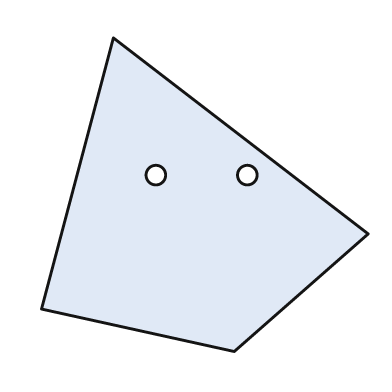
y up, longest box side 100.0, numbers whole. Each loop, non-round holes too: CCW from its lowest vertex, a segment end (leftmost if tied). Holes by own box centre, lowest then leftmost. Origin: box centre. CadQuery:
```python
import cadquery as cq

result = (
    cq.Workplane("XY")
    .moveTo(9.0, -48.0)
    .lineTo(50.0, -12.0)
    .lineTo(-28.0, 48.0)
    .lineTo(-50.0, -35.0)
    .close()
    .moveTo(-15.0, 6.0)
    .circle(3.0)
    .moveTo(13.0, 6.0)
    .circle(3.0)
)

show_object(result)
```